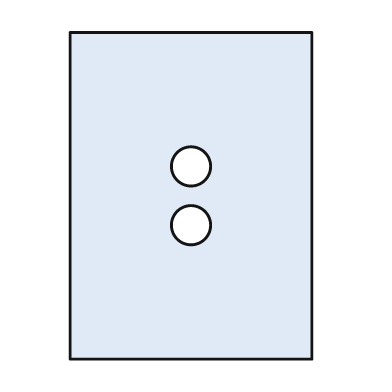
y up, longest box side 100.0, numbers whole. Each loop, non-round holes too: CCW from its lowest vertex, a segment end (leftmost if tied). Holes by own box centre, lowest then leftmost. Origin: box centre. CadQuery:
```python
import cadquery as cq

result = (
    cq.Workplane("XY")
    .moveTo(-37.0, -50.0)
    .lineTo(37.0, -50.0)
    .lineTo(37.0, 50.0)
    .lineTo(-37.0, 50.0)
    .close()
    .moveTo(0.0, -9.0)
    .circle(6.0)
    .moveTo(0.0, 9.0)
    .circle(6.0)
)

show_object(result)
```